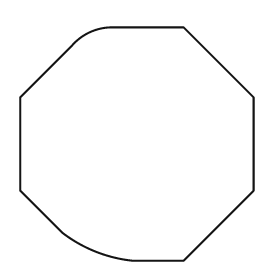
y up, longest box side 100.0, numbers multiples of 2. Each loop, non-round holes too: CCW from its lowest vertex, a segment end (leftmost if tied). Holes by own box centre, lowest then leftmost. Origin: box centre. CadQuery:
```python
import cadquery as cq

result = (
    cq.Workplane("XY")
    .moveTo(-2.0, -50.0)
    .lineTo(20.0, -50.0)
    .lineTo(50.0, -20.0)
    .lineTo(50.0, 20.0)
    .lineTo(20.0, 50.0)
    .lineTo(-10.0, 50.0)
    .threePointArc((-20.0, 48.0), (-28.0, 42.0))
    .lineTo(-50.0, 20.0)
    .lineTo(-50.0, -20.0)
    .lineTo(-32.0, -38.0)
    .threePointArc((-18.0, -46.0), (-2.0, -50.0))
    .close()
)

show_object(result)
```